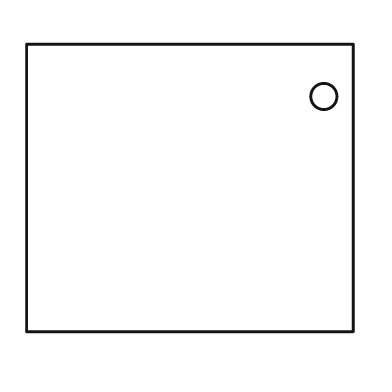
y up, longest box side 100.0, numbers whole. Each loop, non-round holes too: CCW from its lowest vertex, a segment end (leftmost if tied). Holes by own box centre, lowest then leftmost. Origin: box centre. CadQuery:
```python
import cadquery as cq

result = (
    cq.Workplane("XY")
    .moveTo(-50.0, -44.0)
    .lineTo(50.0, -44.0)
    .lineTo(50.0, 44.0)
    .lineTo(-50.0, 44.0)
    .close()
    .moveTo(41.0, 28.0)
    .circle(4.0)
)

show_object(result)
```